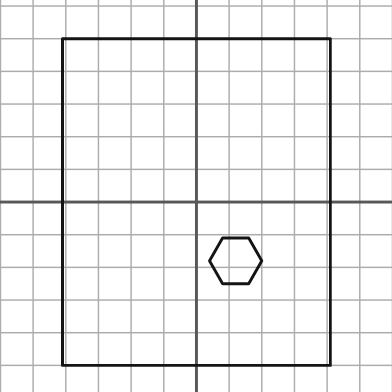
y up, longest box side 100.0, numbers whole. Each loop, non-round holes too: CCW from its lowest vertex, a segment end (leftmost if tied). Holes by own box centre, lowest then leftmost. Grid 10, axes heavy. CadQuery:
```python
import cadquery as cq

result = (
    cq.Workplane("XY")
    .moveTo(-41.0, -50.0)
    .lineTo(41.0, -50.0)
    .lineTo(41.0, 50.0)
    .lineTo(-41.0, 50.0)
    .close()
    .moveTo(8.0, -25.0)
    .lineTo(16.0, -25.0)
    .lineTo(20.0, -18.0)
    .lineTo(16.0, -11.0)
    .lineTo(8.0, -11.0)
    .lineTo(4.0, -18.0)
    .close()
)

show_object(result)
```